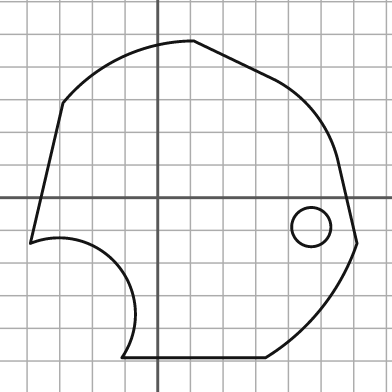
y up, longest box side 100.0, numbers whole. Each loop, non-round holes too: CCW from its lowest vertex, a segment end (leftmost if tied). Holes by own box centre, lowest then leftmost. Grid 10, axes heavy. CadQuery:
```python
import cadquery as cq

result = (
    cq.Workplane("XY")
    .moveTo(-11.0, -49.0)
    .lineTo(33.0, -49.0)
    .threePointArc((50.0, -34.0), (61.0, -14.0))
    .lineTo(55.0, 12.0)
    .threePointArc((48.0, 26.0), (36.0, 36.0))
    .lineTo(11.0, 48.0)
    .threePointArc((-11.0, 43.0), (-29.0, 29.0))
    .lineTo(-39.0, -14.0)
    .threePointArc((-12.0, -21.0), (-11.0, -49.0))
    .close()
    .moveTo(47.0, -9.0)
    .circle(6.0)
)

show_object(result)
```